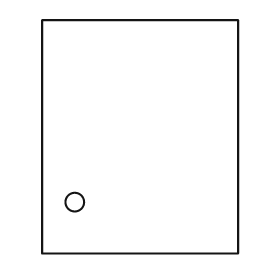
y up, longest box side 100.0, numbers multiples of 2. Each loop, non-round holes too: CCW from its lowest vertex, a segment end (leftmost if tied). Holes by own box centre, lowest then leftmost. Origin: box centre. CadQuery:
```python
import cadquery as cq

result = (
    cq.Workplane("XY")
    .moveTo(-42.0, -50.0)
    .lineTo(42.0, -50.0)
    .lineTo(42.0, 50.0)
    .lineTo(-42.0, 50.0)
    .close()
    .moveTo(-28.0, -28.0)
    .circle(4.0)
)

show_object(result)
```